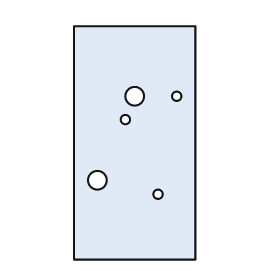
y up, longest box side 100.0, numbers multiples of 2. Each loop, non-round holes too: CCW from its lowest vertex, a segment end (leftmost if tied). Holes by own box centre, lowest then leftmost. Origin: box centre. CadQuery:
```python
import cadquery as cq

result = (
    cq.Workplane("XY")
    .moveTo(-26.0, -50.0)
    .lineTo(26.0, -50.0)
    .lineTo(26.0, 50.0)
    .lineTo(-26.0, 50.0)
    .close()
    .moveTo(10.0, -22.0)
    .circle(2.0)
    .moveTo(-16.0, -16.0)
    .circle(4.0)
    .moveTo(-4.0, 10.0)
    .circle(2.0)
    .moveTo(0.0, 20.0)
    .circle(4.0)
    .moveTo(18.0, 20.0)
    .circle(2.0)
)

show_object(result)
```